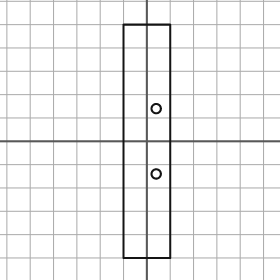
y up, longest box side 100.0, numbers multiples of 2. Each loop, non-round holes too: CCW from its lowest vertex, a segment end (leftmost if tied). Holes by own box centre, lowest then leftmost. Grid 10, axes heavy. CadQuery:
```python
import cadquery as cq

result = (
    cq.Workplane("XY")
    .moveTo(-10.0, -50.0)
    .lineTo(10.0, -50.0)
    .lineTo(10.0, 50.0)
    .lineTo(-10.0, 50.0)
    .close()
    .moveTo(4.0, -14.0)
    .circle(2.0)
    .moveTo(4.0, 14.0)
    .circle(2.0)
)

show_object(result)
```